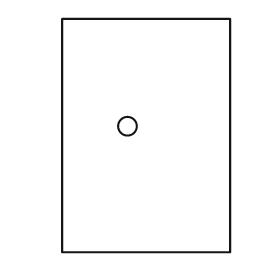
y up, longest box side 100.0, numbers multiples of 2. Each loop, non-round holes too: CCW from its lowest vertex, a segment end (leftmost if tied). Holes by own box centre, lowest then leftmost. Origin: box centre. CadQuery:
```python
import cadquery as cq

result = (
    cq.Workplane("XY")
    .moveTo(-36.0, -50.0)
    .lineTo(36.0, -50.0)
    .lineTo(36.0, 50.0)
    .lineTo(-36.0, 50.0)
    .close()
    .moveTo(-8.0, 4.0)
    .circle(4.0)
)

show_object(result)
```